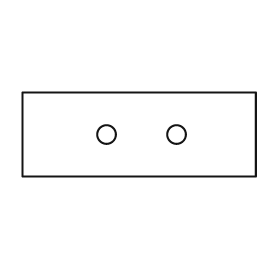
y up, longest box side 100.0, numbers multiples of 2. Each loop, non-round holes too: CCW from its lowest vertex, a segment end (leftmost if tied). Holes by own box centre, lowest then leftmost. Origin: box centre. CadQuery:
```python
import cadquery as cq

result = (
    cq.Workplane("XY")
    .moveTo(-50.0, -18.0)
    .lineTo(50.0, -18.0)
    .lineTo(50.0, 18.0)
    .lineTo(-50.0, 18.0)
    .close()
    .moveTo(-14.0, 0.0)
    .circle(4.0)
    .moveTo(16.0, 0.0)
    .circle(4.0)
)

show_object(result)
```